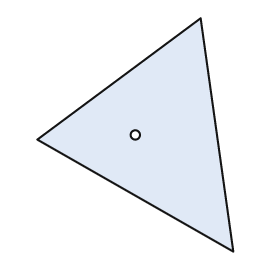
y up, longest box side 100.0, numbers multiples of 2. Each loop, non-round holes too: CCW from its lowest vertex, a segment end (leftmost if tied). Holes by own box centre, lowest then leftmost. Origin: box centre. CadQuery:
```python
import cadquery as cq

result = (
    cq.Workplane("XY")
    .moveTo(42.0, -50.0)
    .lineTo(28.0, 50.0)
    .lineTo(-42.0, -2.0)
    .close()
    .moveTo(0.0, 0.0)
    .circle(2.0)
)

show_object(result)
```